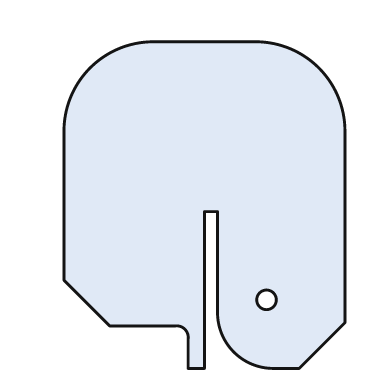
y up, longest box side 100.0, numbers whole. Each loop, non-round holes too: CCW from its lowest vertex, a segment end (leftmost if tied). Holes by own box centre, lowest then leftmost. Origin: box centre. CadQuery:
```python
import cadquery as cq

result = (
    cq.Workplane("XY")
    .moveTo(-5.0, -50.0)
    .lineTo(0.0, -50.0)
    .lineTo(0.0, -2.0)
    .lineTo(4.0, -2.0)
    .lineTo(4.0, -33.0)
    .threePointArc((9.0, -45.0), (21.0, -50.0))
    .lineTo(29.0, -50.0)
    .lineTo(43.0, -36.0)
    .lineTo(43.0, 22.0)
    .threePointArc((35.0, 42.0), (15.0, 50.0))
    .lineTo(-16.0, 50.0)
    .threePointArc((-35.0, 42.0), (-43.0, 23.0))
    .lineTo(-43.0, -23.0)
    .lineTo(-29.0, -37.0)
    .lineTo(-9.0, -37.0)
    .threePointArc((-6.0, -38.0), (-5.0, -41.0))
    .close()
    .moveTo(19.0, -29.0)
    .circle(3.0)
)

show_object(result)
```